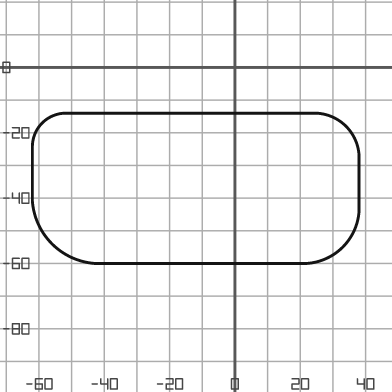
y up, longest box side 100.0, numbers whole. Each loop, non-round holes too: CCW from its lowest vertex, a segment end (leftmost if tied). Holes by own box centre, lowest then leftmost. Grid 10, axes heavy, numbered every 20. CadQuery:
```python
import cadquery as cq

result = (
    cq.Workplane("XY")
    .moveTo(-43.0, -60.0)
    .lineTo(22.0, -60.0)
    .threePointArc((33.0, -55.0), (38.0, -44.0))
    .lineTo(38.0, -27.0)
    .threePointArc((34.0, -18.0), (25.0, -14.0))
    .lineTo(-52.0, -14.0)
    .threePointArc((-59.0, -17.0), (-62.0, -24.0))
    .lineTo(-62.0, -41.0)
    .threePointArc((-56.0, -54.0), (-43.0, -60.0))
    .close()
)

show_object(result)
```